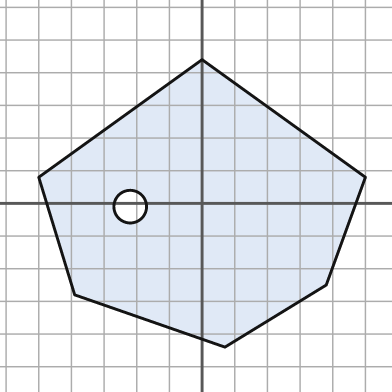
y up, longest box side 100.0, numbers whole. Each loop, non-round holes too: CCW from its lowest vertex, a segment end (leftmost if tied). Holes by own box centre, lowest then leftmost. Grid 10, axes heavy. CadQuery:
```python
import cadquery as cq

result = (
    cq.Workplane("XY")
    .moveTo(7.0, -44.0)
    .lineTo(38.0, -25.0)
    .lineTo(50.0, 8.0)
    .lineTo(0.0, 44.0)
    .lineTo(-50.0, 8.0)
    .lineTo(-39.0, -28.0)
    .close()
    .moveTo(-22.0, -1.0)
    .circle(5.0)
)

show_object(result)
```